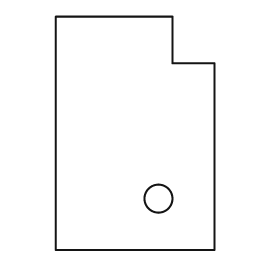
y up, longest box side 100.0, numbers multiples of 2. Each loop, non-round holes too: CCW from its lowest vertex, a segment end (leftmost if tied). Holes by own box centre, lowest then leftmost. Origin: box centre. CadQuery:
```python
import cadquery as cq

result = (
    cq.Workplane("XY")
    .moveTo(-34.0, -50.0)
    .lineTo(34.0, -50.0)
    .lineTo(34.0, 30.0)
    .lineTo(16.0, 30.0)
    .lineTo(16.0, 50.0)
    .lineTo(-34.0, 50.0)
    .close()
    .moveTo(10.0, -28.0)
    .circle(6.0)
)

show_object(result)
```